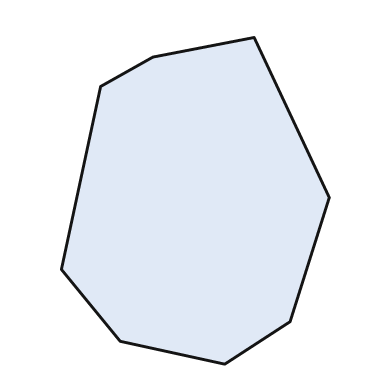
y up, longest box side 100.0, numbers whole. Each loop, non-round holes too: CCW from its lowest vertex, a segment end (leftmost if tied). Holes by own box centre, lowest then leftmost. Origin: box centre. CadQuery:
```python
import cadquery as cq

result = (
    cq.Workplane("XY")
    .moveTo(9.0, -50.0)
    .lineTo(29.0, -37.0)
    .lineTo(41.0, 1.0)
    .lineTo(18.0, 50.0)
    .lineTo(-13.0, 44.0)
    .lineTo(-29.0, 35.0)
    .lineTo(-41.0, -21.0)
    .lineTo(-23.0, -43.0)
    .close()
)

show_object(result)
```